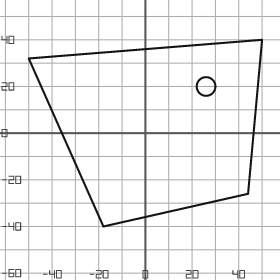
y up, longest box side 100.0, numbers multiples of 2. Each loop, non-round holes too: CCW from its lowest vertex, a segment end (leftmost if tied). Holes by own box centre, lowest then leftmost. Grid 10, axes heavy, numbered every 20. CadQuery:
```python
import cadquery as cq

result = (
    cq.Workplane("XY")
    .moveTo(-18.0, -40.0)
    .lineTo(44.0, -26.0)
    .lineTo(50.0, 40.0)
    .lineTo(-50.0, 32.0)
    .close()
    .moveTo(26.0, 20.0)
    .circle(4.0)
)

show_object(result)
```